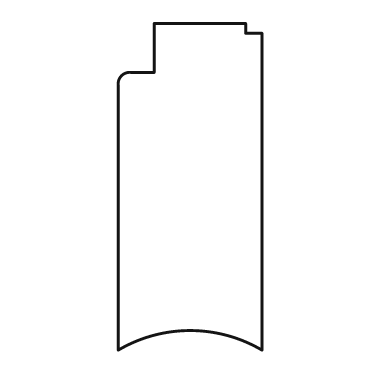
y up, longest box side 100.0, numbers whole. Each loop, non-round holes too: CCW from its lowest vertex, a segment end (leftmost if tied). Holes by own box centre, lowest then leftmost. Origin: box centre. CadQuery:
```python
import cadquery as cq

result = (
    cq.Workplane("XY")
    .moveTo(-22.0, -50.0)
    .threePointArc((0.0, -44.0), (22.0, -50.0))
    .lineTo(22.0, 47.0)
    .lineTo(17.0, 47.0)
    .lineTo(17.0, 50.0)
    .lineTo(-11.0, 50.0)
    .lineTo(-11.0, 35.0)
    .lineTo(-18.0, 35.0)
    .threePointArc((-21.0, 34.0), (-22.0, 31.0))
    .close()
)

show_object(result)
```